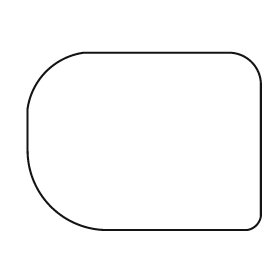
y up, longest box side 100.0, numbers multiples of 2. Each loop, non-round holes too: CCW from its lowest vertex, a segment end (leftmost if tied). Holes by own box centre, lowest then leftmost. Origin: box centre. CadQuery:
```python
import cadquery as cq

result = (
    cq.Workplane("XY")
    .moveTo(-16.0, -38.0)
    .lineTo(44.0, -38.0)
    .threePointArc((48.0, -36.0), (50.0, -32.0))
    .lineTo(50.0, 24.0)
    .threePointArc((46.0, 34.0), (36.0, 38.0))
    .lineTo(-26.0, 38.0)
    .threePointArc((-42.0, 30.0), (-50.0, 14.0))
    .lineTo(-50.0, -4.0)
    .threePointArc((-40.0, -28.0), (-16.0, -38.0))
    .close()
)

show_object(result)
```